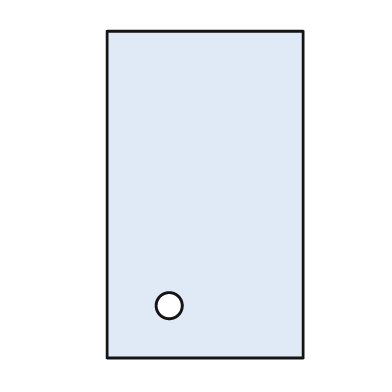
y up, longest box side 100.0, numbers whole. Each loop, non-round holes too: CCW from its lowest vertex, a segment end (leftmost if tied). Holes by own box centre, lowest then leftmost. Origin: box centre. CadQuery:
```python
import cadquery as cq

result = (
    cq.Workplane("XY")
    .moveTo(-30.0, -50.0)
    .lineTo(30.0, -50.0)
    .lineTo(30.0, 50.0)
    .lineTo(-30.0, 50.0)
    .close()
    .moveTo(-11.0, -34.0)
    .circle(4.0)
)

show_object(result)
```